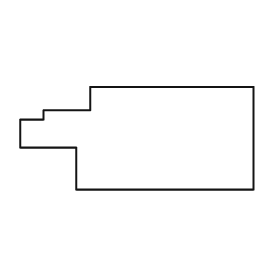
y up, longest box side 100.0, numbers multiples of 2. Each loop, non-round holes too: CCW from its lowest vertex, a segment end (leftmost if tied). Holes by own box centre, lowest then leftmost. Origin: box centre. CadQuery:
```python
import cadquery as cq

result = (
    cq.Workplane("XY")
    .moveTo(-26.0, -22.0)
    .lineTo(50.0, -22.0)
    .lineTo(50.0, 22.0)
    .lineTo(-20.0, 22.0)
    .lineTo(-20.0, 12.0)
    .lineTo(-40.0, 12.0)
    .lineTo(-40.0, 8.0)
    .lineTo(-50.0, 8.0)
    .lineTo(-50.0, -4.0)
    .lineTo(-26.0, -4.0)
    .close()
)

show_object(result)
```